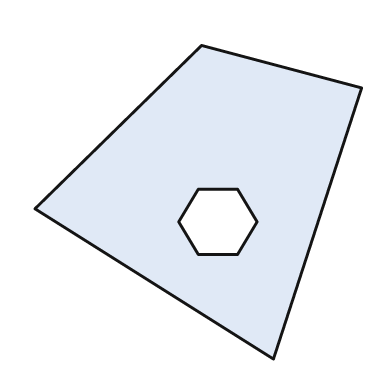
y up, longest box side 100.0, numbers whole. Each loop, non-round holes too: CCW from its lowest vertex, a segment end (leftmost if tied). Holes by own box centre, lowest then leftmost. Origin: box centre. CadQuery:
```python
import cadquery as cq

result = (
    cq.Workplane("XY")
    .moveTo(23.0, -48.0)
    .lineTo(50.0, 35.0)
    .lineTo(1.0, 48.0)
    .lineTo(-50.0, -2.0)
    .close()
    .moveTo(0.0, -16.0)
    .lineTo(12.0, -16.0)
    .lineTo(18.0, -6.0)
    .lineTo(12.0, 4.0)
    .lineTo(0.0, 4.0)
    .lineTo(-6.0, -6.0)
    .close()
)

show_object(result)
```